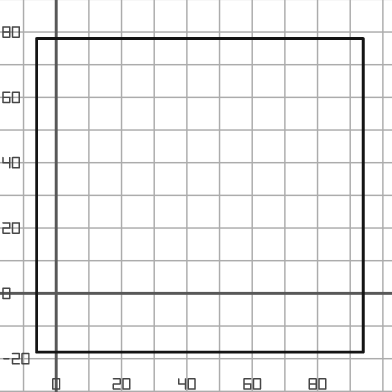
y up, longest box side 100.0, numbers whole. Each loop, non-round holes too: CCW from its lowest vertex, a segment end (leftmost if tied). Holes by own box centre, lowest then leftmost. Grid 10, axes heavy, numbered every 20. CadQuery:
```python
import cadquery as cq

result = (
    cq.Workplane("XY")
    .moveTo(-6.0, -18.0)
    .lineTo(94.0, -18.0)
    .lineTo(94.0, 78.0)
    .lineTo(-6.0, 78.0)
    .close()
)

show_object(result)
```